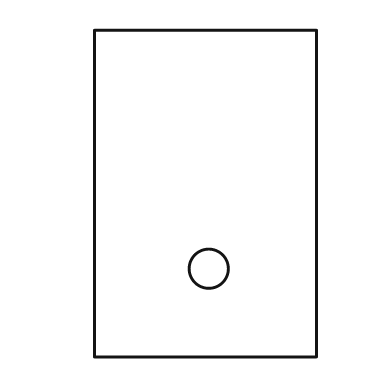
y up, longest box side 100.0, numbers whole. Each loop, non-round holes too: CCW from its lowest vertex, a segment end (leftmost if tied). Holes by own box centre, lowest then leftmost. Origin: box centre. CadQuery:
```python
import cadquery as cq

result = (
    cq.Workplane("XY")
    .moveTo(-34.0, -50.0)
    .lineTo(34.0, -50.0)
    .lineTo(34.0, 50.0)
    .lineTo(-34.0, 50.0)
    .close()
    .moveTo(1.0, -23.0)
    .circle(6.0)
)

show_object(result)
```